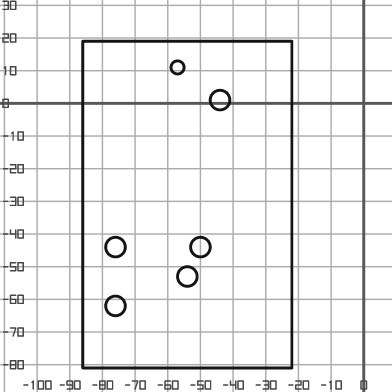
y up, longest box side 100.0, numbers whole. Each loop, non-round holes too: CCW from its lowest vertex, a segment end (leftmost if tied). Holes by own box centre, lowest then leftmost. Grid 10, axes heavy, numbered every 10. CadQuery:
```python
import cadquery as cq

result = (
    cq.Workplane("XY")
    .moveTo(-86.0, -81.0)
    .lineTo(-22.0, -81.0)
    .lineTo(-22.0, 19.0)
    .lineTo(-86.0, 19.0)
    .close()
    .moveTo(-76.0, -62.0)
    .circle(3.0)
    .moveTo(-54.0, -53.0)
    .circle(3.0)
    .moveTo(-76.0, -44.0)
    .circle(3.0)
    .moveTo(-50.0, -44.0)
    .circle(3.0)
    .moveTo(-44.0, 1.0)
    .circle(3.0)
    .moveTo(-57.0, 11.0)
    .circle(2.0)
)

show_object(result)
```